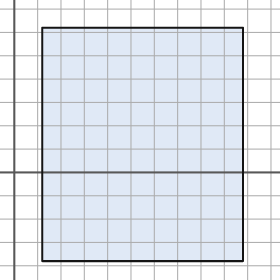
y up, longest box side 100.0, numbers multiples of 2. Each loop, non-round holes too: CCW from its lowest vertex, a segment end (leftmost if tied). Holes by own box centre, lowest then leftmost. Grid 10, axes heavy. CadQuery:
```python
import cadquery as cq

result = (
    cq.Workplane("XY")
    .moveTo(12.0, -38.0)
    .lineTo(98.0, -38.0)
    .lineTo(98.0, 62.0)
    .lineTo(12.0, 62.0)
    .close()
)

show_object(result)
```